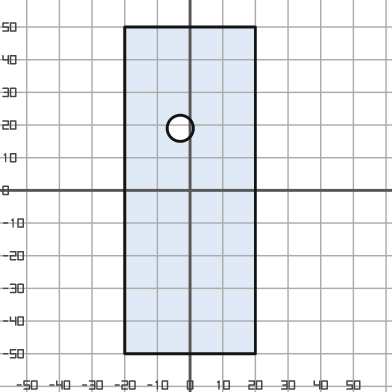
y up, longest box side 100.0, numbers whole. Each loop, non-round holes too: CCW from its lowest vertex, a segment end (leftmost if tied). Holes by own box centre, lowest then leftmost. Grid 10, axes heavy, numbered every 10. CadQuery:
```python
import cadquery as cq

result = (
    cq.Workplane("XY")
    .moveTo(-20.0, -50.0)
    .lineTo(20.0, -50.0)
    .lineTo(20.0, 50.0)
    .lineTo(-20.0, 50.0)
    .close()
    .moveTo(-3.0, 19.0)
    .circle(4.0)
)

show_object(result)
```